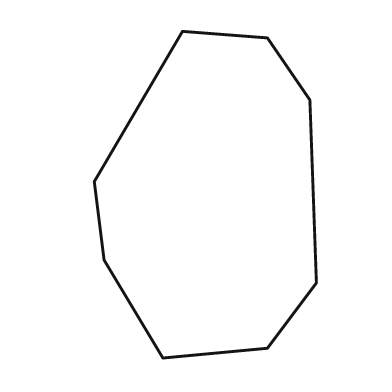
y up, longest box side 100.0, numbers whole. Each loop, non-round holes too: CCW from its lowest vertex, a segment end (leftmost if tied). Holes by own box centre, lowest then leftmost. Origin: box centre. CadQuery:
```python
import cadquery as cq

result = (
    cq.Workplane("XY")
    .moveTo(-13.0, -50.0)
    .lineTo(19.0, -47.0)
    .lineTo(34.0, -27.0)
    .lineTo(32.0, 29.0)
    .lineTo(19.0, 48.0)
    .lineTo(-7.0, 50.0)
    .lineTo(-34.0, 4.0)
    .lineTo(-31.0, -20.0)
    .close()
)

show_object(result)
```